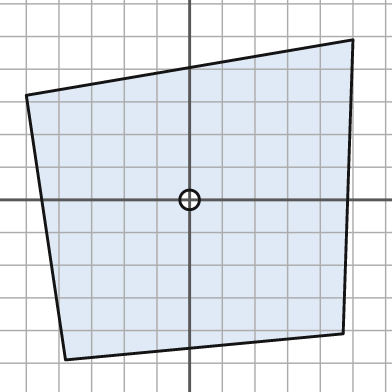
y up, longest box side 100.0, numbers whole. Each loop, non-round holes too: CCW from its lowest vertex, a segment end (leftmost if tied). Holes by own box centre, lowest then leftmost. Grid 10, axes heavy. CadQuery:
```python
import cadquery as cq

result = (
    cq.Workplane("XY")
    .moveTo(-38.0, -49.0)
    .lineTo(47.0, -41.0)
    .lineTo(50.0, 49.0)
    .lineTo(-50.0, 32.0)
    .close()
    .moveTo(0.0, 0.0)
    .circle(3.0)
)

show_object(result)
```